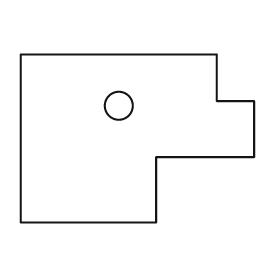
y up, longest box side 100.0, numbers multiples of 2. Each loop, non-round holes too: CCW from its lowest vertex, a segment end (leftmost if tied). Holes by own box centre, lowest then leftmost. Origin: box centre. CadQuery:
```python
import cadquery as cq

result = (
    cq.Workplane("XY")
    .moveTo(-50.0, -36.0)
    .lineTo(8.0, -36.0)
    .lineTo(8.0, -8.0)
    .lineTo(50.0, -8.0)
    .lineTo(50.0, 16.0)
    .lineTo(34.0, 16.0)
    .lineTo(34.0, 36.0)
    .lineTo(-50.0, 36.0)
    .close()
    .moveTo(-8.0, 14.0)
    .circle(6.0)
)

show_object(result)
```